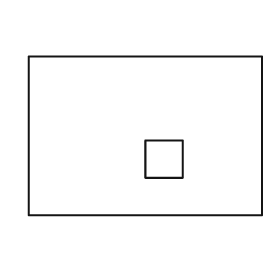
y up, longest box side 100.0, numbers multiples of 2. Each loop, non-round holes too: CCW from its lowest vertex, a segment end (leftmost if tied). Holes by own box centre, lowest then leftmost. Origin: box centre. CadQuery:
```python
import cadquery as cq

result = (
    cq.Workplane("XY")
    .moveTo(-50.0, -34.0)
    .lineTo(50.0, -34.0)
    .lineTo(50.0, 34.0)
    .lineTo(-50.0, 34.0)
    .close()
    .moveTo(0.0, -18.0)
    .lineTo(16.0, -18.0)
    .lineTo(16.0, -2.0)
    .lineTo(0.0, -2.0)
    .close()
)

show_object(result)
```